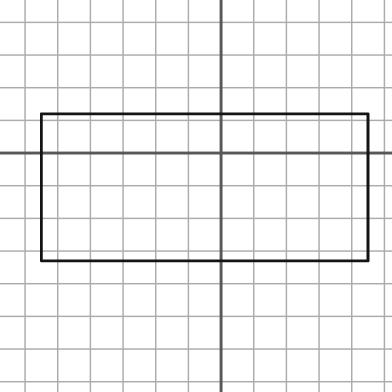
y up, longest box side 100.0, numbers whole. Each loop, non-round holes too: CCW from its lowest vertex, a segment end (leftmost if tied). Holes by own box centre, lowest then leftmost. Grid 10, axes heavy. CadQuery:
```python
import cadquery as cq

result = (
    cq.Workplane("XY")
    .moveTo(-55.0, -33.0)
    .lineTo(45.0, -33.0)
    .lineTo(45.0, 12.0)
    .lineTo(-55.0, 12.0)
    .close()
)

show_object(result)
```